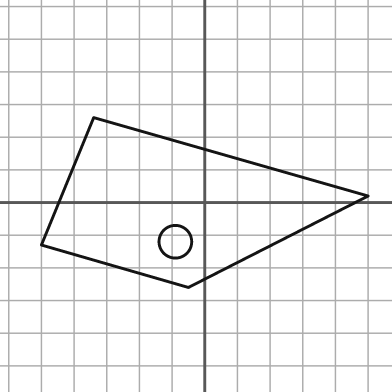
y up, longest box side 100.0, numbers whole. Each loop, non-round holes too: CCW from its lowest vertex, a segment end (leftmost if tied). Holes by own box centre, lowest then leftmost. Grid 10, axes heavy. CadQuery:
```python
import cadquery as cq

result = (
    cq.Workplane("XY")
    .moveTo(-5.0, -26.0)
    .lineTo(50.0, 2.0)
    .lineTo(-34.0, 26.0)
    .lineTo(-50.0, -13.0)
    .close()
    .moveTo(-9.0, -12.0)
    .circle(5.0)
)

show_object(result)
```